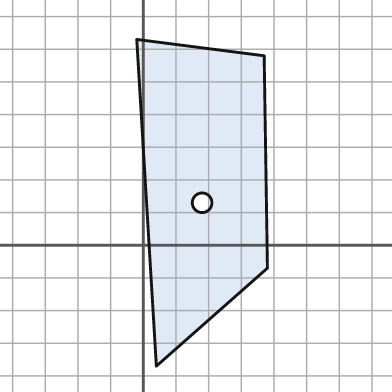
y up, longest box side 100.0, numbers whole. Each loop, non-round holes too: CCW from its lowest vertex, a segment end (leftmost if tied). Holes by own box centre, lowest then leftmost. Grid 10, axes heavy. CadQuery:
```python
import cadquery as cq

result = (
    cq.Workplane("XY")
    .moveTo(4.0, -37.0)
    .lineTo(38.0, -7.0)
    .lineTo(37.0, 58.0)
    .lineTo(-2.0, 63.0)
    .close()
    .moveTo(18.0, 13.0)
    .circle(3.0)
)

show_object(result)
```